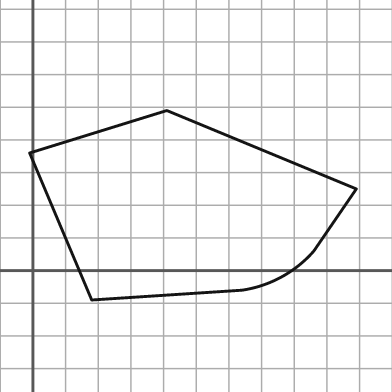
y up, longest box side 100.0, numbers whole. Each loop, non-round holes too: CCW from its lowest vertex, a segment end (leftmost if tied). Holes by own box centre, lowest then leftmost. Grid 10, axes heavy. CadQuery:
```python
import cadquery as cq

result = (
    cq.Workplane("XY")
    .moveTo(18.0, -9.0)
    .lineTo(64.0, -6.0)
    .threePointArc((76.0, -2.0), (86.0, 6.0))
    .lineTo(99.0, 25.0)
    .lineTo(41.0, 49.0)
    .lineTo(-1.0, 36.0)
    .close()
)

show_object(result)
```